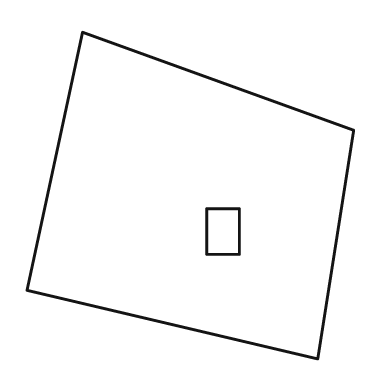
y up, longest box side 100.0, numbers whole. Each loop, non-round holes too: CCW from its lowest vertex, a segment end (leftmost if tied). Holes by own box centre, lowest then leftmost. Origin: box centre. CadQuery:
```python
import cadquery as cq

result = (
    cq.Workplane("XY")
    .moveTo(39.0, -50.0)
    .lineTo(50.0, 20.0)
    .lineTo(-33.0, 50.0)
    .lineTo(-50.0, -29.0)
    .close()
    .moveTo(5.0, -18.0)
    .lineTo(15.0, -18.0)
    .lineTo(15.0, -4.0)
    .lineTo(5.0, -4.0)
    .close()
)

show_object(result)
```